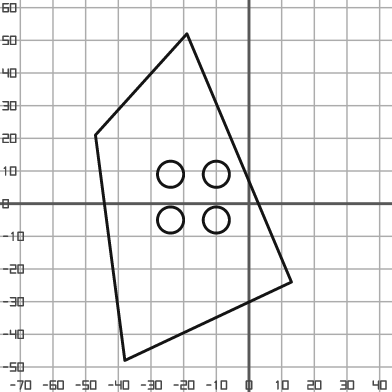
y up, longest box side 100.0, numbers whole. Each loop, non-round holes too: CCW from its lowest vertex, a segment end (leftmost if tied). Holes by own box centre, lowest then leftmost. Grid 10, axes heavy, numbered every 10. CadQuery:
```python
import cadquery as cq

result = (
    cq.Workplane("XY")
    .moveTo(-38.0, -48.0)
    .lineTo(13.0, -24.0)
    .lineTo(-19.0, 52.0)
    .lineTo(-47.0, 21.0)
    .close()
    .moveTo(-24.0, -5.0)
    .circle(4.0)
    .moveTo(-10.0, -5.0)
    .circle(4.0)
    .moveTo(-24.0, 9.0)
    .circle(4.0)
    .moveTo(-10.0, 9.0)
    .circle(4.0)
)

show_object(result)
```